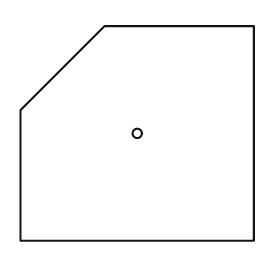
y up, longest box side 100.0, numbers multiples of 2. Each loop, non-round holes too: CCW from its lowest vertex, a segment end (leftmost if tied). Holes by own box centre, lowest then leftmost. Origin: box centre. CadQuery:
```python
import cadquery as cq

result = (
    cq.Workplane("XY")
    .moveTo(-50.0, -46.0)
    .lineTo(50.0, -46.0)
    .lineTo(50.0, 46.0)
    .lineTo(-14.0, 46.0)
    .lineTo(-50.0, 10.0)
    .close()
    .moveTo(0.0, 0.0)
    .circle(2.0)
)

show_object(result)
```